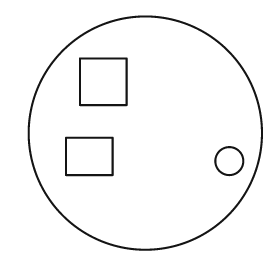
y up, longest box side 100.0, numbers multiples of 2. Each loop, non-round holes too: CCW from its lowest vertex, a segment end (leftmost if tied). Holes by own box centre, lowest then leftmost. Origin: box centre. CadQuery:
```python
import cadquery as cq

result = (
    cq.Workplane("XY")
    .moveTo(0.0, 0.0)
    .circle(50.0)
    .moveTo(36.0, -12.0)
    .circle(6.0)
    .moveTo(-34.0, -18.0)
    .lineTo(-14.0, -18.0)
    .lineTo(-14.0, -2.0)
    .lineTo(-34.0, -2.0)
    .close()
    .moveTo(-28.0, 12.0)
    .lineTo(-8.0, 12.0)
    .lineTo(-8.0, 32.0)
    .lineTo(-28.0, 32.0)
    .close()
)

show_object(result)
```